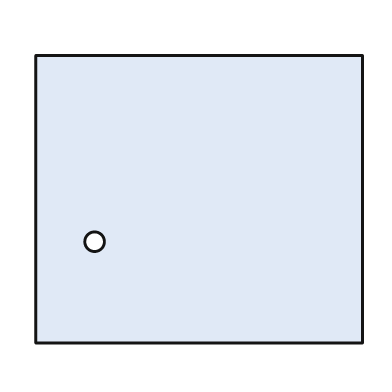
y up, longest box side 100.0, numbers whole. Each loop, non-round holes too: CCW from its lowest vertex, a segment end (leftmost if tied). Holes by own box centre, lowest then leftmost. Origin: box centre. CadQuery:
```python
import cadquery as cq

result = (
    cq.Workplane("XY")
    .moveTo(-50.0, -44.0)
    .lineTo(50.0, -44.0)
    .lineTo(50.0, 44.0)
    .lineTo(-50.0, 44.0)
    .close()
    .moveTo(-32.0, -13.0)
    .circle(3.0)
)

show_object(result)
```